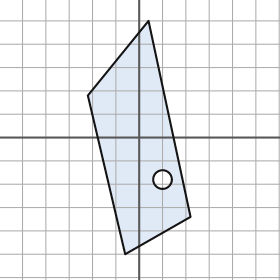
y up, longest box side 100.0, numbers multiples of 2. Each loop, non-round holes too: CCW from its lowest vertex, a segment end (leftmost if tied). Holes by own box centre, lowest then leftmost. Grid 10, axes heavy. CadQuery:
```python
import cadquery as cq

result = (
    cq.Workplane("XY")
    .moveTo(-6.0, -50.0)
    .lineTo(22.0, -34.0)
    .lineTo(4.0, 50.0)
    .lineTo(-22.0, 18.0)
    .close()
    .moveTo(10.0, -18.0)
    .circle(4.0)
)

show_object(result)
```